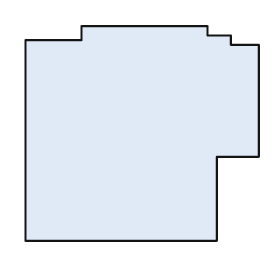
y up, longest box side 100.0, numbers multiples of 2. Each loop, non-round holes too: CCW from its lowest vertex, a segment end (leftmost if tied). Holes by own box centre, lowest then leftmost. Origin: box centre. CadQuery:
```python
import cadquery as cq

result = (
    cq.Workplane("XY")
    .moveTo(-50.0, -46.0)
    .lineTo(32.0, -46.0)
    .lineTo(32.0, -10.0)
    .lineTo(50.0, -10.0)
    .lineTo(50.0, 38.0)
    .lineTo(38.0, 38.0)
    .lineTo(38.0, 42.0)
    .lineTo(28.0, 42.0)
    .lineTo(28.0, 46.0)
    .lineTo(-26.0, 46.0)
    .lineTo(-26.0, 40.0)
    .lineTo(-50.0, 40.0)
    .close()
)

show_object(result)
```